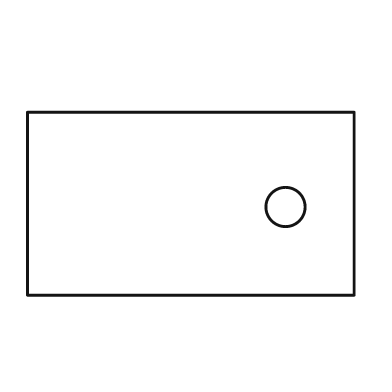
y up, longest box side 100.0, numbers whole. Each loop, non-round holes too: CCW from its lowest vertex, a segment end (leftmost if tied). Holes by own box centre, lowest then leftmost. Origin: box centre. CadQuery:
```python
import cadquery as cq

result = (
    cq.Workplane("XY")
    .moveTo(-50.0, -28.0)
    .lineTo(50.0, -28.0)
    .lineTo(50.0, 28.0)
    .lineTo(-50.0, 28.0)
    .close()
    .moveTo(29.0, -1.0)
    .circle(6.0)
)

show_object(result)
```